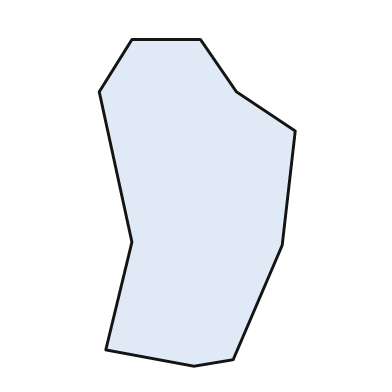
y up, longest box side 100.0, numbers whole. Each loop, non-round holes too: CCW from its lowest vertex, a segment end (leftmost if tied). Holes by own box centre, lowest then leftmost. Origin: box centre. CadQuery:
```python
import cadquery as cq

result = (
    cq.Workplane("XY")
    .moveTo(-1.0, -50.0)
    .lineTo(11.0, -48.0)
    .lineTo(26.0, -13.0)
    .lineTo(30.0, 22.0)
    .lineTo(12.0, 34.0)
    .lineTo(1.0, 50.0)
    .lineTo(-20.0, 50.0)
    .lineTo(-30.0, 34.0)
    .lineTo(-20.0, -12.0)
    .lineTo(-28.0, -45.0)
    .close()
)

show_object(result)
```